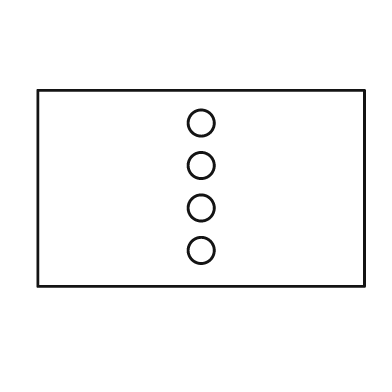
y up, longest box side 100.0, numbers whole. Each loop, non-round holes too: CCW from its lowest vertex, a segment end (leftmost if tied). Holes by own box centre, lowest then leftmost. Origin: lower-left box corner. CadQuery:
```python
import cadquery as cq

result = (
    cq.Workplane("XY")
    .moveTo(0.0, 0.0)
    .lineTo(100.0, 0.0)
    .lineTo(100.0, 60.0)
    .lineTo(0.0, 60.0)
    .close()
    .moveTo(50.0, 11.0)
    .circle(4.0)
    .moveTo(50.0, 24.0)
    .circle(4.0)
    .moveTo(50.0, 37.0)
    .circle(4.0)
    .moveTo(50.0, 50.0)
    .circle(4.0)
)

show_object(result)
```